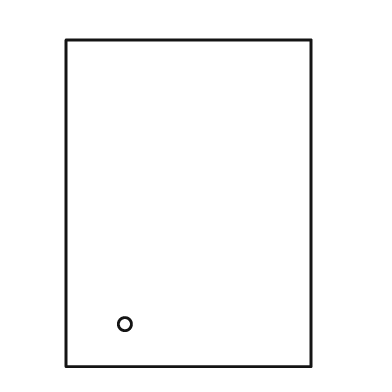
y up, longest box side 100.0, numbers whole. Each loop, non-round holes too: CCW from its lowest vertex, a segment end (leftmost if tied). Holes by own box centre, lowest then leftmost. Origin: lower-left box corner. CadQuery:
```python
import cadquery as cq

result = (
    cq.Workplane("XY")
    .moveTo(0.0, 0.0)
    .lineTo(75.0, 0.0)
    .lineTo(75.0, 100.0)
    .lineTo(0.0, 100.0)
    .close()
    .moveTo(18.0, 13.0)
    .circle(2.0)
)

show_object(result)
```